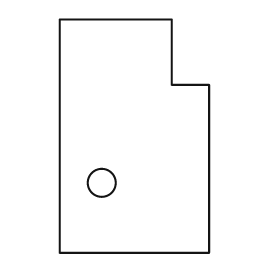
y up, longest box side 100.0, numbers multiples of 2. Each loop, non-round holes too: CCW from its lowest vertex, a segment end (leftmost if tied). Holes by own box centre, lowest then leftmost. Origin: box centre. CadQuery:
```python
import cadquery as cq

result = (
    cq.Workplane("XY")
    .moveTo(-32.0, -50.0)
    .lineTo(32.0, -50.0)
    .lineTo(32.0, 22.0)
    .lineTo(16.0, 22.0)
    .lineTo(16.0, 50.0)
    .lineTo(-32.0, 50.0)
    .close()
    .moveTo(-14.0, -20.0)
    .circle(6.0)
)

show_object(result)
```